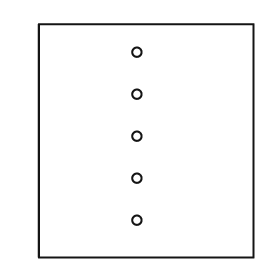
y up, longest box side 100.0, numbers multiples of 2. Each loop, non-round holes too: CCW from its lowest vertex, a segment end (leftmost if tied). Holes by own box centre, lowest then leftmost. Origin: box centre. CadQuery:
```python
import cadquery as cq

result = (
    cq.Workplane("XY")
    .moveTo(-46.0, -50.0)
    .lineTo(46.0, -50.0)
    .lineTo(46.0, 50.0)
    .lineTo(-46.0, 50.0)
    .close()
    .moveTo(-4.0, -34.0)
    .circle(2.0)
    .moveTo(-4.0, -16.0)
    .circle(2.0)
    .moveTo(-4.0, 2.0)
    .circle(2.0)
    .moveTo(-4.0, 20.0)
    .circle(2.0)
    .moveTo(-4.0, 38.0)
    .circle(2.0)
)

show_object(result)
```